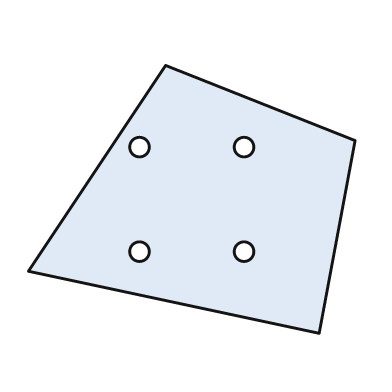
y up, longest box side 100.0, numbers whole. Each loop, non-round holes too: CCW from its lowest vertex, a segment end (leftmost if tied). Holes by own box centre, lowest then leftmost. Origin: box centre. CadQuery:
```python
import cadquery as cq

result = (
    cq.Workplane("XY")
    .moveTo(39.0, -41.0)
    .lineTo(50.0, 18.0)
    .lineTo(-8.0, 41.0)
    .lineTo(-50.0, -22.0)
    .close()
    .moveTo(-16.0, -16.0)
    .circle(3.0)
    .moveTo(16.0, -16.0)
    .circle(3.0)
    .moveTo(-16.0, 16.0)
    .circle(3.0)
    .moveTo(16.0, 16.0)
    .circle(3.0)
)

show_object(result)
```